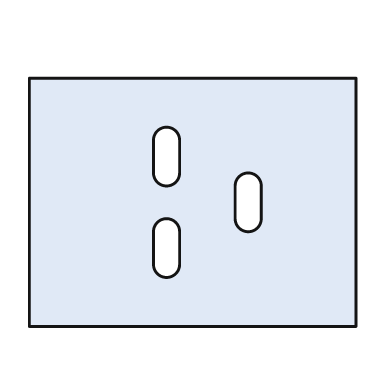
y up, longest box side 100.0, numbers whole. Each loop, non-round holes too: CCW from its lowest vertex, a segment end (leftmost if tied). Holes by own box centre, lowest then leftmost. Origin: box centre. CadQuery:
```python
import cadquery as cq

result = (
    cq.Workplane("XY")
    .moveTo(-50.0, -38.0)
    .lineTo(50.0, -38.0)
    .lineTo(50.0, 38.0)
    .lineTo(-50.0, 38.0)
    .close()
    .moveTo(-12.0, -19.0)
    .threePointArc((-8.0, -23.0), (-4.0, -19.0))
    .lineTo(-4.0, -9.0)
    .threePointArc((-8.0, -5.0), (-12.0, -9.0))
    .close()
    .moveTo(13.0, -5.0)
    .threePointArc((17.0, -9.0), (21.0, -5.0))
    .lineTo(21.0, 5.0)
    .threePointArc((17.0, 9.0), (13.0, 5.0))
    .close()
    .moveTo(-12.0, 9.0)
    .threePointArc((-8.0, 5.0), (-4.0, 9.0))
    .lineTo(-4.0, 19.0)
    .threePointArc((-8.0, 23.0), (-12.0, 19.0))
    .close()
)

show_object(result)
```